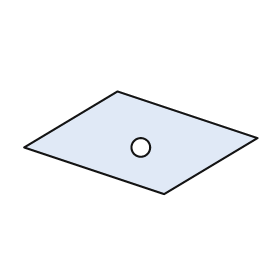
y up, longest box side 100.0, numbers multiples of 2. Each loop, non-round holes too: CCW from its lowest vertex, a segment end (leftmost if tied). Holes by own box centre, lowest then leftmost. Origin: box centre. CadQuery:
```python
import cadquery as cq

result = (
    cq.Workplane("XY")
    .moveTo(10.0, -22.0)
    .lineTo(50.0, 2.0)
    .lineTo(-10.0, 22.0)
    .lineTo(-50.0, -2.0)
    .close()
    .moveTo(0.0, -2.0)
    .circle(4.0)
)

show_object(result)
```